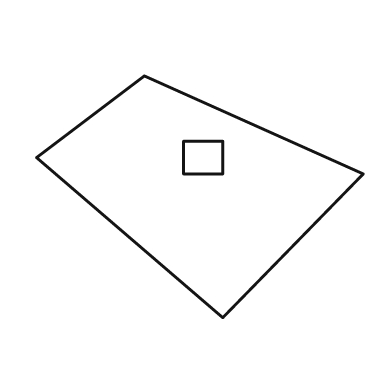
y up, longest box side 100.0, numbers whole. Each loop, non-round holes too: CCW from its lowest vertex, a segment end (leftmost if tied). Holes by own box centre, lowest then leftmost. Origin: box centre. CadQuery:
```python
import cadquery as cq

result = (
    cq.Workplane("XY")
    .moveTo(7.0, -37.0)
    .lineTo(50.0, 7.0)
    .lineTo(-17.0, 37.0)
    .lineTo(-50.0, 12.0)
    .close()
    .moveTo(-5.0, 7.0)
    .lineTo(7.0, 7.0)
    .lineTo(7.0, 17.0)
    .lineTo(-5.0, 17.0)
    .close()
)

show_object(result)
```